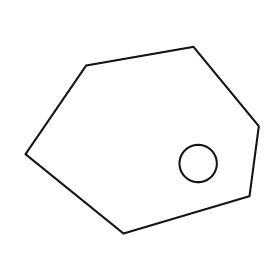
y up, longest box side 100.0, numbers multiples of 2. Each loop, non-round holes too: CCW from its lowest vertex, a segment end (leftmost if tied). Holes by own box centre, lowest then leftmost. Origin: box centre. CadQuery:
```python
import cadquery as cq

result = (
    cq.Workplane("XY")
    .moveTo(-8.0, -40.0)
    .lineTo(46.0, -24.0)
    .lineTo(50.0, 6.0)
    .lineTo(22.0, 40.0)
    .lineTo(-24.0, 32.0)
    .lineTo(-50.0, -6.0)
    .close()
    .moveTo(24.0, -10.0)
    .circle(8.0)
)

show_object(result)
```